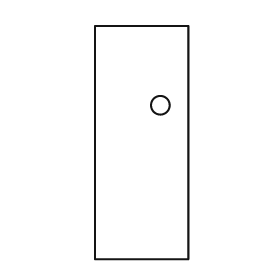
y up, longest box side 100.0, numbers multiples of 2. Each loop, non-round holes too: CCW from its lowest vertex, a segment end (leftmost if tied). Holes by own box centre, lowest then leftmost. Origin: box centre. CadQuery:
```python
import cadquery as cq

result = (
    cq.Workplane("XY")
    .moveTo(-20.0, -50.0)
    .lineTo(20.0, -50.0)
    .lineTo(20.0, 50.0)
    .lineTo(-20.0, 50.0)
    .close()
    .moveTo(8.0, 16.0)
    .circle(4.0)
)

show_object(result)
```